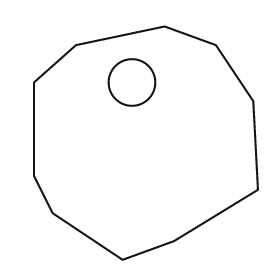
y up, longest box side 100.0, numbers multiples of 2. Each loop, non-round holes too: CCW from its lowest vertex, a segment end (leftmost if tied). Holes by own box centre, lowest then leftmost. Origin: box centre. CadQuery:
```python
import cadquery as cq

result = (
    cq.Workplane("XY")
    .moveTo(-10.0, -50.0)
    .lineTo(12.0, -42.0)
    .lineTo(48.0, -20.0)
    .lineTo(46.0, 18.0)
    .lineTo(30.0, 42.0)
    .lineTo(8.0, 50.0)
    .lineTo(-30.0, 42.0)
    .lineTo(-48.0, 26.0)
    .lineTo(-48.0, -14.0)
    .lineTo(-40.0, -30.0)
    .close()
    .moveTo(-6.0, 26.0)
    .circle(10.0)
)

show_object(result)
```